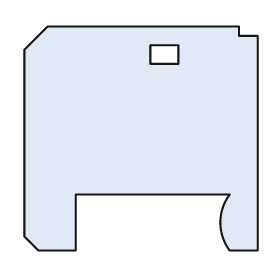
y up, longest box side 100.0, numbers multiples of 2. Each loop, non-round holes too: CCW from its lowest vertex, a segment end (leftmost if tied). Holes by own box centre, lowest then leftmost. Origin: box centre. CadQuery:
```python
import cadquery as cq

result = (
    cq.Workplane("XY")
    .moveTo(-44.0, -48.0)
    .lineTo(-28.0, -48.0)
    .lineTo(-28.0, -24.0)
    .lineTo(38.0, -24.0)
    .threePointArc((34.0, -36.0), (38.0, -48.0))
    .lineTo(50.0, -48.0)
    .lineTo(50.0, 44.0)
    .lineTo(42.0, 44.0)
    .lineTo(42.0, 48.0)
    .lineTo(-40.0, 48.0)
    .lineTo(-50.0, 38.0)
    .lineTo(-50.0, -42.0)
    .close()
    .moveTo(4.0, 32.0)
    .lineTo(16.0, 32.0)
    .lineTo(16.0, 40.0)
    .lineTo(4.0, 40.0)
    .close()
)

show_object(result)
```